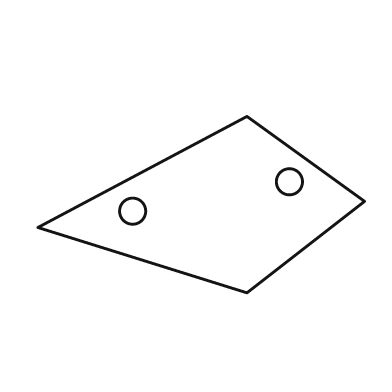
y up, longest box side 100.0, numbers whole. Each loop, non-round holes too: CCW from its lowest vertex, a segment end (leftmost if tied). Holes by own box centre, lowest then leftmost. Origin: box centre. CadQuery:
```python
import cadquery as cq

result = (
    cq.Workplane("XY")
    .moveTo(14.0, -27.0)
    .lineTo(50.0, 1.0)
    .lineTo(14.0, 27.0)
    .lineTo(-50.0, -7.0)
    .close()
    .moveTo(-21.0, -2.0)
    .circle(4.0)
    .moveTo(27.0, 7.0)
    .circle(4.0)
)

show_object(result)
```